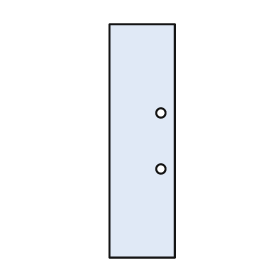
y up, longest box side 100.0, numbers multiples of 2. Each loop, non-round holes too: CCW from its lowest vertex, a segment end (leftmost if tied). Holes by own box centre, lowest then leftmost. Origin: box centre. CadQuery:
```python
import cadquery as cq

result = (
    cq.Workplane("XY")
    .moveTo(-14.0, -50.0)
    .lineTo(14.0, -50.0)
    .lineTo(14.0, 50.0)
    .lineTo(-14.0, 50.0)
    .close()
    .moveTo(8.0, -12.0)
    .circle(2.0)
    .moveTo(8.0, 12.0)
    .circle(2.0)
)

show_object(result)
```